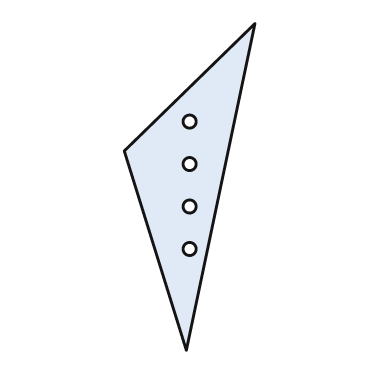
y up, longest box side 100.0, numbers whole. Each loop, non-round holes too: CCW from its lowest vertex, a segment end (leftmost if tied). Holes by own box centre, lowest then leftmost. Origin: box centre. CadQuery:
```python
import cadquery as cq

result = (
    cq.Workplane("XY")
    .moveTo(-1.0, -50.0)
    .lineTo(20.0, 50.0)
    .lineTo(-20.0, 11.0)
    .close()
    .moveTo(0.0, -19.0)
    .circle(2.0)
    .moveTo(0.0, -6.0)
    .circle(2.0)
    .moveTo(0.0, 7.0)
    .circle(2.0)
    .moveTo(0.0, 20.0)
    .circle(2.0)
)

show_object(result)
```